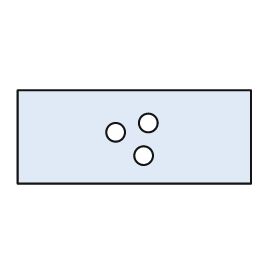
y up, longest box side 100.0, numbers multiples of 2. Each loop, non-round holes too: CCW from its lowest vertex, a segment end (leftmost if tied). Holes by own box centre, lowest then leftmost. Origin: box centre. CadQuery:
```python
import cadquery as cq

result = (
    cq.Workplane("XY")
    .moveTo(-50.0, -20.0)
    .lineTo(50.0, -20.0)
    .lineTo(50.0, 20.0)
    .lineTo(-50.0, 20.0)
    .close()
    .moveTo(4.0, -8.0)
    .circle(4.0)
    .moveTo(-8.0, 2.0)
    .circle(4.0)
    .moveTo(6.0, 6.0)
    .circle(4.0)
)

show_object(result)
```